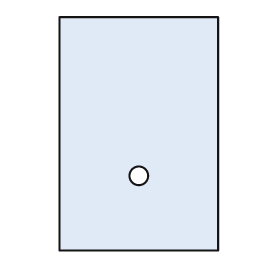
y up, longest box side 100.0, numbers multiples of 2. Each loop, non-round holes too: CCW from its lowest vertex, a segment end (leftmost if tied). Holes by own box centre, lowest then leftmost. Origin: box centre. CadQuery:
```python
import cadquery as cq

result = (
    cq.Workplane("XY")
    .moveTo(-34.0, -50.0)
    .lineTo(34.0, -50.0)
    .lineTo(34.0, 50.0)
    .lineTo(-34.0, 50.0)
    .close()
    .moveTo(0.0, -18.0)
    .circle(4.0)
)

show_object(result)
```